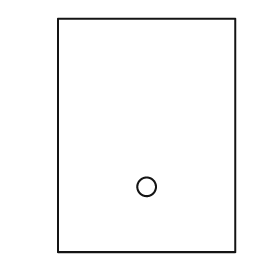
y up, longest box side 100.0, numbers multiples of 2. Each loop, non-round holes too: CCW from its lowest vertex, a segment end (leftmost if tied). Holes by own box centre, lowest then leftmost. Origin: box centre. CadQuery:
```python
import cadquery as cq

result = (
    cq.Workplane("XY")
    .moveTo(-38.0, -50.0)
    .lineTo(38.0, -50.0)
    .lineTo(38.0, 50.0)
    .lineTo(-38.0, 50.0)
    .close()
    .moveTo(0.0, -22.0)
    .circle(4.0)
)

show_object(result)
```